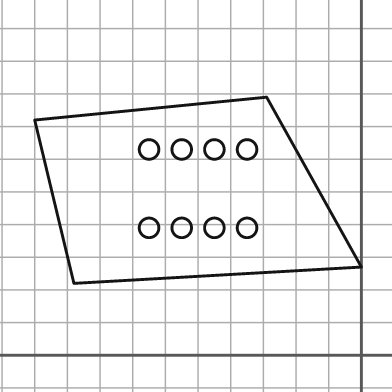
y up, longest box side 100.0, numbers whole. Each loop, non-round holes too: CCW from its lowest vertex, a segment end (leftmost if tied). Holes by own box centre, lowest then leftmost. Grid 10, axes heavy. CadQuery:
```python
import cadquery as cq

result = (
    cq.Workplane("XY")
    .moveTo(-88.0, 22.0)
    .lineTo(0.0, 27.0)
    .lineTo(-29.0, 79.0)
    .lineTo(-100.0, 72.0)
    .close()
    .moveTo(-65.0, 39.0)
    .circle(3.0)
    .moveTo(-55.0, 39.0)
    .circle(3.0)
    .moveTo(-45.0, 39.0)
    .circle(3.0)
    .moveTo(-35.0, 39.0)
    .circle(3.0)
    .moveTo(-65.0, 63.0)
    .circle(3.0)
    .moveTo(-55.0, 63.0)
    .circle(3.0)
    .moveTo(-45.0, 63.0)
    .circle(3.0)
    .moveTo(-35.0, 63.0)
    .circle(3.0)
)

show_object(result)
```